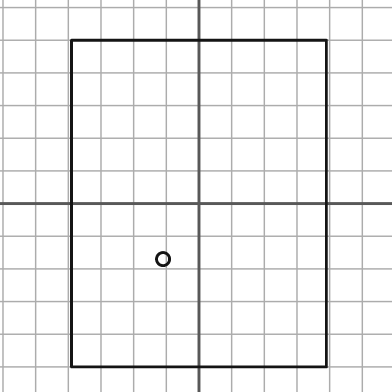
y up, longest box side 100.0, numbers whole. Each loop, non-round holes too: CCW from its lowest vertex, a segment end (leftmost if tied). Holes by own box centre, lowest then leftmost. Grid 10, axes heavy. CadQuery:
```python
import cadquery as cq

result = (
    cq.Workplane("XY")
    .moveTo(-39.0, -50.0)
    .lineTo(39.0, -50.0)
    .lineTo(39.0, 50.0)
    .lineTo(-39.0, 50.0)
    .close()
    .moveTo(-11.0, -17.0)
    .circle(2.0)
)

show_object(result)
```